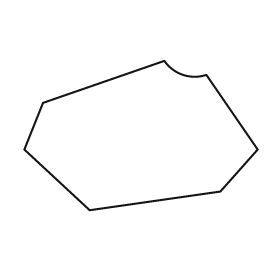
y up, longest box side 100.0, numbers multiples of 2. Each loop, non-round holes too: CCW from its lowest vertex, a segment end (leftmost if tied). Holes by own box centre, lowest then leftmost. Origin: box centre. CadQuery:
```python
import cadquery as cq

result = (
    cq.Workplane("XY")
    .moveTo(-22.0, -32.0)
    .lineTo(34.0, -24.0)
    .lineTo(50.0, -6.0)
    .lineTo(28.0, 26.0)
    .threePointArc((18.0, 26.0), (10.0, 32.0))
    .lineTo(-42.0, 14.0)
    .lineTo(-50.0, -6.0)
    .close()
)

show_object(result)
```